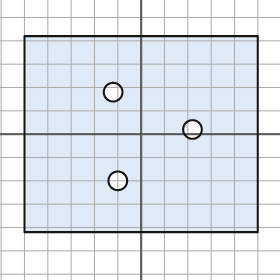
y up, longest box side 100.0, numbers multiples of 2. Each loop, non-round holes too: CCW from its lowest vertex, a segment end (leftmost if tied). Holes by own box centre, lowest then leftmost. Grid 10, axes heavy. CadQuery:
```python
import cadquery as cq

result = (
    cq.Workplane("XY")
    .moveTo(-50.0, -42.0)
    .lineTo(50.0, -42.0)
    .lineTo(50.0, 42.0)
    .lineTo(-50.0, 42.0)
    .close()
    .moveTo(-10.0, -20.0)
    .circle(4.0)
    .moveTo(22.0, 2.0)
    .circle(4.0)
    .moveTo(-12.0, 18.0)
    .circle(4.0)
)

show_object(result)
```